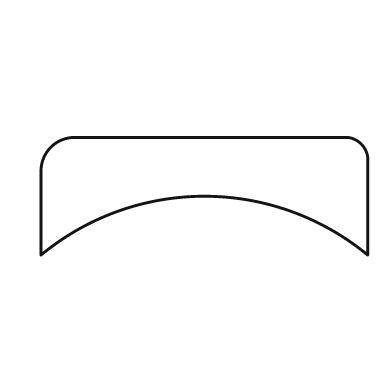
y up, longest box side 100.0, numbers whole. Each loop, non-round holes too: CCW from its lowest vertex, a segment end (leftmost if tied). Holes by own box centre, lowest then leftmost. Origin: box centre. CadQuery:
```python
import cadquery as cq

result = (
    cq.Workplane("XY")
    .moveTo(-50.0, -18.0)
    .threePointArc((0.0, 0.0), (50.0, -18.0))
    .lineTo(50.0, 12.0)
    .threePointArc((48.0, 16.0), (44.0, 18.0))
    .lineTo(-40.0, 18.0)
    .threePointArc((-47.0, 15.0), (-50.0, 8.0))
    .close()
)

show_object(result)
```